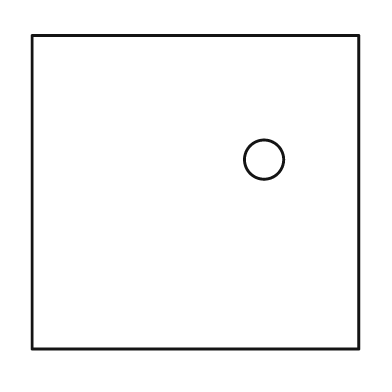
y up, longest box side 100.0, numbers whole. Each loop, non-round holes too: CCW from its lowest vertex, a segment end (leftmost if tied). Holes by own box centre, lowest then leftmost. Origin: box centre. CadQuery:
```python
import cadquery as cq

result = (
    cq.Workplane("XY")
    .moveTo(-50.0, -48.0)
    .lineTo(50.0, -48.0)
    .lineTo(50.0, 48.0)
    .lineTo(-50.0, 48.0)
    .close()
    .moveTo(21.0, 10.0)
    .circle(6.0)
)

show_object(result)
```